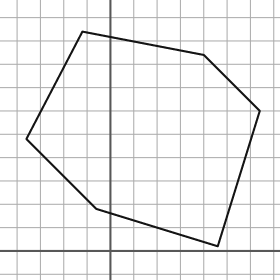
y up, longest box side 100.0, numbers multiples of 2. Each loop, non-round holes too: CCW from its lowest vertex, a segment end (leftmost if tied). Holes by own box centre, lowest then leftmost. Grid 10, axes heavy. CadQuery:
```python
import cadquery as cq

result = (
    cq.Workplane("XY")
    .moveTo(46.0, 2.0)
    .lineTo(64.0, 60.0)
    .lineTo(40.0, 84.0)
    .lineTo(-12.0, 94.0)
    .lineTo(-36.0, 48.0)
    .lineTo(-6.0, 18.0)
    .close()
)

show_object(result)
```